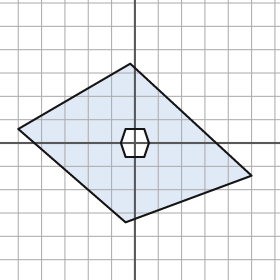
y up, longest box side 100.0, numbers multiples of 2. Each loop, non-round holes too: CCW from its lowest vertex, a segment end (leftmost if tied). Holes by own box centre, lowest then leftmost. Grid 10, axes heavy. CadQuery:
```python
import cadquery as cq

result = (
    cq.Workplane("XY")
    .moveTo(-4.0, -34.0)
    .lineTo(50.0, -14.0)
    .lineTo(-2.0, 34.0)
    .lineTo(-50.0, 6.0)
    .close()
    .moveTo(-4.0, -6.0)
    .lineTo(4.0, -6.0)
    .lineTo(6.0, 0.0)
    .lineTo(4.0, 6.0)
    .lineTo(-4.0, 6.0)
    .lineTo(-6.0, 0.0)
    .close()
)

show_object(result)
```